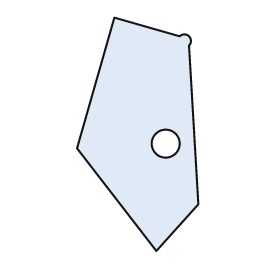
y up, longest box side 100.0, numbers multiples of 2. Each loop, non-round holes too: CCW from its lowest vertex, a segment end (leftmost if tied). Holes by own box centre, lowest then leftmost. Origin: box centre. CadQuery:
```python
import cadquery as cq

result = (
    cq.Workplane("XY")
    .moveTo(8.0, -50.0)
    .lineTo(26.0, -30.0)
    .lineTo(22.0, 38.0)
    .threePointArc((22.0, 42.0), (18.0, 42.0))
    .lineTo(-10.0, 50.0)
    .lineTo(-26.0, -6.0)
    .close()
    .moveTo(12.0, -4.0)
    .circle(6.0)
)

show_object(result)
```